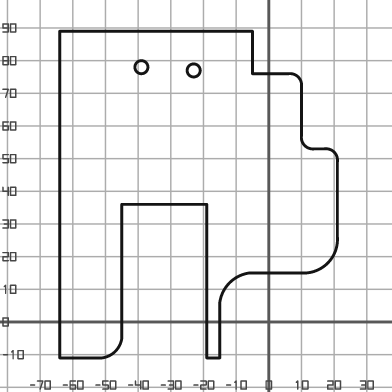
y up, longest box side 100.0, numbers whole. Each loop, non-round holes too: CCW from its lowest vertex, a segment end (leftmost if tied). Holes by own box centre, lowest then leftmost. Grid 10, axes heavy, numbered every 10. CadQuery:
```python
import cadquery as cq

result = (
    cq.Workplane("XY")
    .moveTo(-64.0, -11.0)
    .lineTo(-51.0, -11.0)
    .threePointArc((-47.0, -9.0), (-45.0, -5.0))
    .lineTo(-45.0, 36.0)
    .lineTo(-19.0, 36.0)
    .lineTo(-19.0, -11.0)
    .lineTo(-15.0, -11.0)
    .lineTo(-15.0, 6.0)
    .threePointArc((-12.0, 12.0), (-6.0, 15.0))
    .lineTo(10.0, 15.0)
    .threePointArc((18.0, 18.0), (21.0, 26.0))
    .lineTo(21.0, 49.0)
    .threePointArc((20.0, 52.0), (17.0, 53.0))
    .lineTo(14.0, 53.0)
    .threePointArc((11.0, 54.0), (10.0, 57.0))
    .lineTo(10.0, 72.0)
    .threePointArc((9.0, 75.0), (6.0, 76.0))
    .lineTo(-5.0, 76.0)
    .lineTo(-5.0, 89.0)
    .lineTo(-64.0, 89.0)
    .close()
    .moveTo(-23.0, 77.0)
    .circle(2.0)
    .moveTo(-39.0, 78.0)
    .circle(2.0)
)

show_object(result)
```